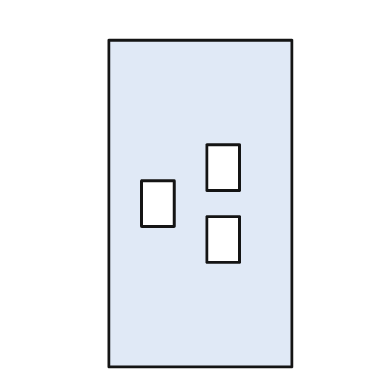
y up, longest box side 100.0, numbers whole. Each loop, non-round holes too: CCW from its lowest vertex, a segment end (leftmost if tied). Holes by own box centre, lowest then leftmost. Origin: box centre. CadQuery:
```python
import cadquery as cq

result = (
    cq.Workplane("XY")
    .moveTo(-28.0, -50.0)
    .lineTo(28.0, -50.0)
    .lineTo(28.0, 50.0)
    .lineTo(-28.0, 50.0)
    .close()
    .moveTo(2.0, -18.0)
    .lineTo(12.0, -18.0)
    .lineTo(12.0, -4.0)
    .lineTo(2.0, -4.0)
    .close()
    .moveTo(-18.0, -7.0)
    .lineTo(-8.0, -7.0)
    .lineTo(-8.0, 7.0)
    .lineTo(-18.0, 7.0)
    .close()
    .moveTo(2.0, 4.0)
    .lineTo(12.0, 4.0)
    .lineTo(12.0, 18.0)
    .lineTo(2.0, 18.0)
    .close()
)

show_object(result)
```